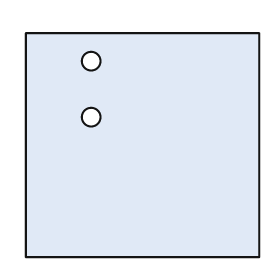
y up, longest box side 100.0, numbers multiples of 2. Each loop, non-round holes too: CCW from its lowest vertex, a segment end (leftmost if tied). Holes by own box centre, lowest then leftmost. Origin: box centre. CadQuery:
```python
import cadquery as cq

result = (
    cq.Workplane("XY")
    .moveTo(-50.0, -48.0)
    .lineTo(50.0, -48.0)
    .lineTo(50.0, 48.0)
    .lineTo(-50.0, 48.0)
    .close()
    .moveTo(-22.0, 12.0)
    .circle(4.0)
    .moveTo(-22.0, 36.0)
    .circle(4.0)
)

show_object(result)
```